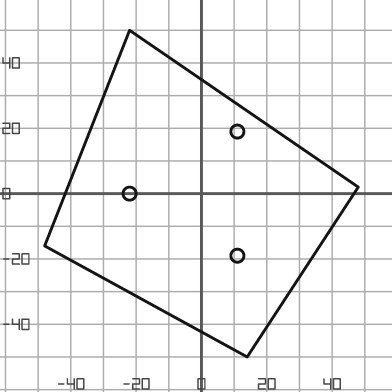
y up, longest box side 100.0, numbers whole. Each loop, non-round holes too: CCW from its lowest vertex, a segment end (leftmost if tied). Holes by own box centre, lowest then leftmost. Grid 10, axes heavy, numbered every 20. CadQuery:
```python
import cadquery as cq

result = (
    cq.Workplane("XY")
    .moveTo(14.0, -50.0)
    .lineTo(48.0, 2.0)
    .lineTo(-22.0, 50.0)
    .lineTo(-48.0, -16.0)
    .close()
    .moveTo(11.0, -19.0)
    .circle(2.0)
    .moveTo(-22.0, 0.0)
    .circle(2.0)
    .moveTo(11.0, 19.0)
    .circle(2.0)
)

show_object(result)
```